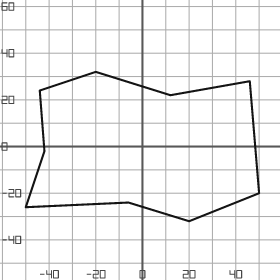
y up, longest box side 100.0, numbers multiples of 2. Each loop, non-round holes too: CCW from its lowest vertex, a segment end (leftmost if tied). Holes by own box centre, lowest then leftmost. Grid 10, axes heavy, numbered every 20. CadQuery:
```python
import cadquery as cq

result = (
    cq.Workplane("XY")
    .moveTo(20.0, -32.0)
    .lineTo(50.0, -20.0)
    .lineTo(46.0, 28.0)
    .lineTo(12.0, 22.0)
    .lineTo(-20.0, 32.0)
    .lineTo(-44.0, 24.0)
    .lineTo(-42.0, -2.0)
    .lineTo(-50.0, -26.0)
    .lineTo(-6.0, -24.0)
    .close()
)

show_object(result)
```